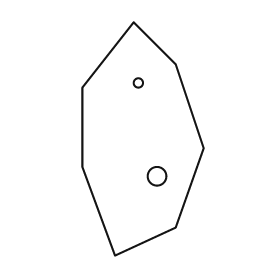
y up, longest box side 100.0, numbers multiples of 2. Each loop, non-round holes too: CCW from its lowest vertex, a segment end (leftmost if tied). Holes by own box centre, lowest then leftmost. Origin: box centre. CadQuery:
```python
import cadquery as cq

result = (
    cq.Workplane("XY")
    .moveTo(-12.0, -50.0)
    .lineTo(14.0, -38.0)
    .lineTo(26.0, -4.0)
    .lineTo(14.0, 32.0)
    .lineTo(-4.0, 50.0)
    .lineTo(-26.0, 22.0)
    .lineTo(-26.0, -12.0)
    .close()
    .moveTo(6.0, -16.0)
    .circle(4.0)
    .moveTo(-2.0, 24.0)
    .circle(2.0)
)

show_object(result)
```